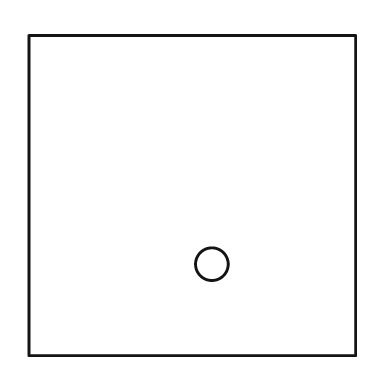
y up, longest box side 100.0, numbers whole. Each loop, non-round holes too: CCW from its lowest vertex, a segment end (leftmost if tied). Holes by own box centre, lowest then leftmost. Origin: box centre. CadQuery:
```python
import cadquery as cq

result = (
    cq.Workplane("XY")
    .moveTo(-50.0, -49.0)
    .lineTo(50.0, -49.0)
    .lineTo(50.0, 49.0)
    .lineTo(-50.0, 49.0)
    .close()
    .moveTo(6.0, -21.0)
    .circle(5.0)
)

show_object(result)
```